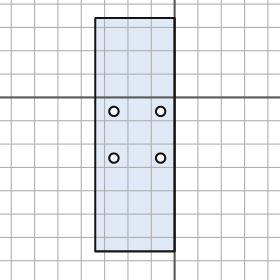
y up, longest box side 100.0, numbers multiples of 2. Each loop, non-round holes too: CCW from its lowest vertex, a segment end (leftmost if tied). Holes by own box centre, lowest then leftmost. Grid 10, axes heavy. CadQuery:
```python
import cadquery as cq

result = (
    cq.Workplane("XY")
    .moveTo(-34.0, -66.0)
    .lineTo(0.0, -66.0)
    .lineTo(0.0, 34.0)
    .lineTo(-34.0, 34.0)
    .close()
    .moveTo(-26.0, -26.0)
    .circle(2.0)
    .moveTo(-6.0, -26.0)
    .circle(2.0)
    .moveTo(-26.0, -6.0)
    .circle(2.0)
    .moveTo(-6.0, -6.0)
    .circle(2.0)
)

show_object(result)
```